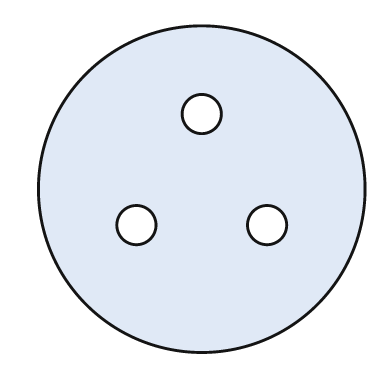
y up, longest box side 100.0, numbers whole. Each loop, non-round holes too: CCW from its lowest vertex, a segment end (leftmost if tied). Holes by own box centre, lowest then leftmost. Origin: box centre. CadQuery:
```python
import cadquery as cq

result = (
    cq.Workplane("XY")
    .moveTo(0.0, 0.0)
    .circle(50.0)
    .moveTo(-20.0, -11.0)
    .circle(6.0)
    .moveTo(20.0, -11.0)
    .circle(6.0)
    .moveTo(0.0, 23.0)
    .circle(6.0)
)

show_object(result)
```